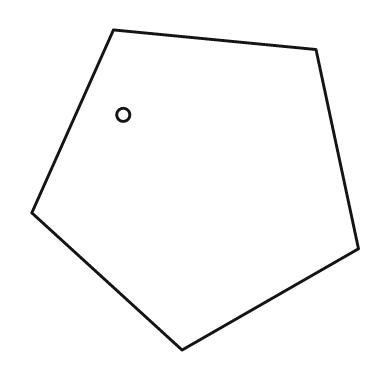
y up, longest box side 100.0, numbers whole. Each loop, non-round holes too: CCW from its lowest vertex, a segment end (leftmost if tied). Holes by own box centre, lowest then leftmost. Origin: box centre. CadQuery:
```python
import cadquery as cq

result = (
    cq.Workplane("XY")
    .moveTo(-4.0, -49.0)
    .lineTo(50.0, -18.0)
    .lineTo(37.0, 43.0)
    .lineTo(-25.0, 49.0)
    .lineTo(-50.0, -7.0)
    .close()
    .moveTo(-22.0, 23.0)
    .circle(2.0)
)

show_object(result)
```